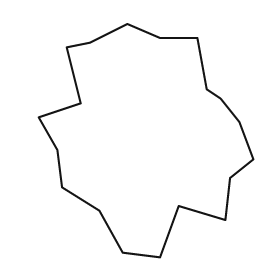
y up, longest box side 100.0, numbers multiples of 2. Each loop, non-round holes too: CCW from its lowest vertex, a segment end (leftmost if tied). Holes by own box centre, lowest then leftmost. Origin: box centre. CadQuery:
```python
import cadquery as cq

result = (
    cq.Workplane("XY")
    .moveTo(6.0, -50.0)
    .lineTo(14.0, -28.0)
    .lineTo(34.0, -34.0)
    .lineTo(36.0, -16.0)
    .lineTo(46.0, -8.0)
    .lineTo(40.0, 8.0)
    .lineTo(32.0, 18.0)
    .lineTo(26.0, 22.0)
    .lineTo(22.0, 44.0)
    .lineTo(6.0, 44.0)
    .lineTo(-8.0, 50.0)
    .lineTo(-24.0, 42.0)
    .lineTo(-34.0, 40.0)
    .lineTo(-28.0, 16.0)
    .lineTo(-46.0, 10.0)
    .lineTo(-38.0, -4.0)
    .lineTo(-36.0, -20.0)
    .lineTo(-20.0, -30.0)
    .lineTo(-10.0, -48.0)
    .close()
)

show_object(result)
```